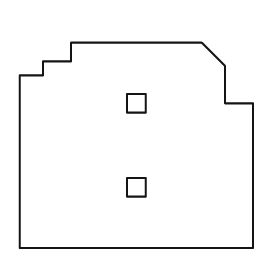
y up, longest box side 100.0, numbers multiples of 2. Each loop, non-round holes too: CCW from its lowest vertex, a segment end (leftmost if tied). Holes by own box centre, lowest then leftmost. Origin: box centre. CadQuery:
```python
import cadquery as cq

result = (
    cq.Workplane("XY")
    .moveTo(-50.0, -44.0)
    .lineTo(50.0, -44.0)
    .lineTo(50.0, 18.0)
    .lineTo(38.0, 18.0)
    .lineTo(38.0, 34.0)
    .lineTo(28.0, 44.0)
    .lineTo(-28.0, 44.0)
    .lineTo(-28.0, 36.0)
    .lineTo(-40.0, 36.0)
    .lineTo(-40.0, 30.0)
    .lineTo(-50.0, 30.0)
    .close()
    .moveTo(-4.0, -22.0)
    .lineTo(4.0, -22.0)
    .lineTo(4.0, -14.0)
    .lineTo(-4.0, -14.0)
    .close()
    .moveTo(-4.0, 14.0)
    .lineTo(4.0, 14.0)
    .lineTo(4.0, 22.0)
    .lineTo(-4.0, 22.0)
    .close()
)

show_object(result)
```